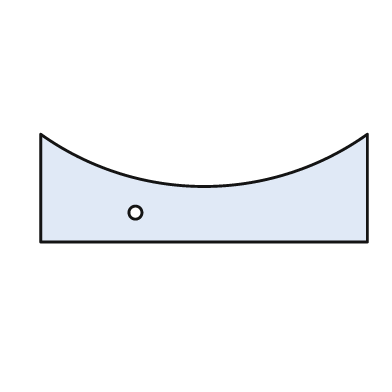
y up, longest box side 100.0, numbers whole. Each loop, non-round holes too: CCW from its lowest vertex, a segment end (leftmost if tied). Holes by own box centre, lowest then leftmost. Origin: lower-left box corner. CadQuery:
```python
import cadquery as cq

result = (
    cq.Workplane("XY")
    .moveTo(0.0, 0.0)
    .lineTo(100.0, 0.0)
    .lineTo(100.0, 33.0)
    .threePointArc((50.0, 17.0), (0.0, 33.0))
    .close()
    .moveTo(29.0, 9.0)
    .circle(2.0)
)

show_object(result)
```